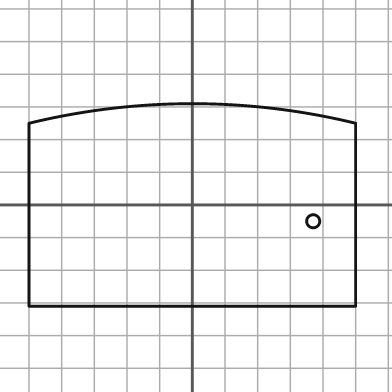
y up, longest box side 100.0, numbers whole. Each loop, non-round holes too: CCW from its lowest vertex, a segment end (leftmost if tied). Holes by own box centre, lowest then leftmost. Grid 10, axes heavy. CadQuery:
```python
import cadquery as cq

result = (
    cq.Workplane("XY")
    .moveTo(-50.0, -31.0)
    .lineTo(50.0, -31.0)
    .lineTo(50.0, 25.0)
    .threePointArc((0.0, 31.0), (-50.0, 25.0))
    .close()
    .moveTo(37.0, -5.0)
    .circle(2.0)
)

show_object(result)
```